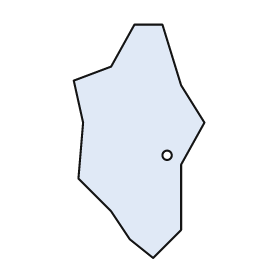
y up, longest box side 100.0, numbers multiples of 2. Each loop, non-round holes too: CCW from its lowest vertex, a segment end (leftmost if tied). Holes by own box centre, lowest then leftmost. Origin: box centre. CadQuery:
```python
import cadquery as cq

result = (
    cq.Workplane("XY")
    .moveTo(6.0, -50.0)
    .lineTo(18.0, -38.0)
    .lineTo(18.0, -10.0)
    .lineTo(28.0, 8.0)
    .lineTo(18.0, 24.0)
    .lineTo(10.0, 50.0)
    .lineTo(-2.0, 50.0)
    .lineTo(-12.0, 32.0)
    .lineTo(-28.0, 26.0)
    .lineTo(-24.0, 8.0)
    .lineTo(-26.0, -16.0)
    .lineTo(-12.0, -30.0)
    .lineTo(-4.0, -42.0)
    .close()
    .moveTo(12.0, -6.0)
    .circle(2.0)
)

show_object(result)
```